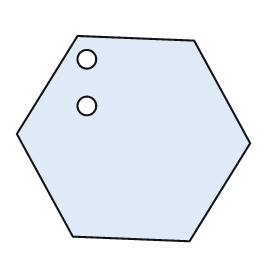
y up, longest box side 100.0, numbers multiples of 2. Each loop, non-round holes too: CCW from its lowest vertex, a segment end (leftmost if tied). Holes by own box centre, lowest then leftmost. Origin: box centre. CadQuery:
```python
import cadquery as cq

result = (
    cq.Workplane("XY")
    .moveTo(24.0, -44.0)
    .lineTo(50.0, -2.0)
    .lineTo(26.0, 42.0)
    .lineTo(-24.0, 44.0)
    .lineTo(-50.0, 2.0)
    .lineTo(-26.0, -42.0)
    .close()
    .moveTo(-20.0, 14.0)
    .circle(4.0)
    .moveTo(-20.0, 34.0)
    .circle(4.0)
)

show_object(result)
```